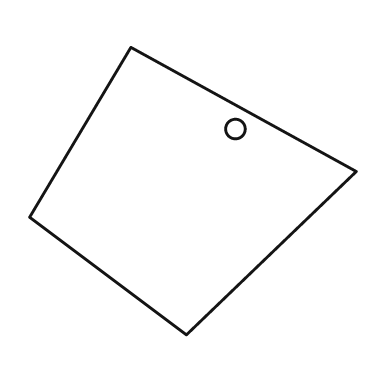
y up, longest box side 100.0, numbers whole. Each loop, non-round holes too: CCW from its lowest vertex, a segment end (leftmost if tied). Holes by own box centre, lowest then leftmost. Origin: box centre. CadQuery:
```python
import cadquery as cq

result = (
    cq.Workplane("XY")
    .moveTo(-2.0, -44.0)
    .lineTo(50.0, 6.0)
    .lineTo(-19.0, 44.0)
    .lineTo(-50.0, -8.0)
    .close()
    .moveTo(13.0, 19.0)
    .circle(3.0)
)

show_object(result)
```